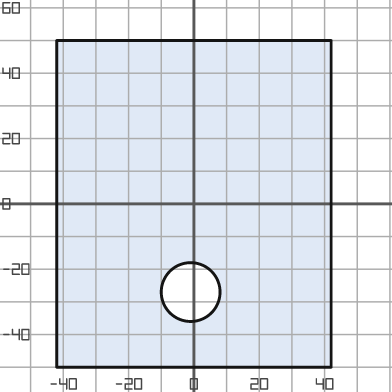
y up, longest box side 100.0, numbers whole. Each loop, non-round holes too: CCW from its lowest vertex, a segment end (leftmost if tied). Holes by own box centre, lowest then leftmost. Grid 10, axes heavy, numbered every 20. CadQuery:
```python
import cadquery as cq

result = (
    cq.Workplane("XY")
    .moveTo(-42.0, -50.0)
    .lineTo(42.0, -50.0)
    .lineTo(42.0, 50.0)
    .lineTo(-42.0, 50.0)
    .close()
    .moveTo(-1.0, -27.0)
    .circle(9.0)
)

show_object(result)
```